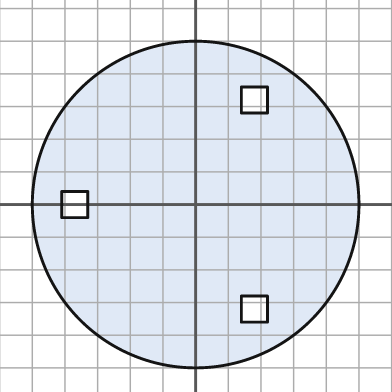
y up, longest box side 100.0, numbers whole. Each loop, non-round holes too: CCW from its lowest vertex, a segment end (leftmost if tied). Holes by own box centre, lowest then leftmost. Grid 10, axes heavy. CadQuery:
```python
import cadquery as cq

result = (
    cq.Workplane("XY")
    .moveTo(0.0, 0.0)
    .circle(50.0)
    .moveTo(14.0, -36.0)
    .lineTo(22.0, -36.0)
    .lineTo(22.0, -28.0)
    .lineTo(14.0, -28.0)
    .close()
    .moveTo(-41.0, -4.0)
    .lineTo(-33.0, -4.0)
    .lineTo(-33.0, 4.0)
    .lineTo(-41.0, 4.0)
    .close()
    .moveTo(14.0, 28.0)
    .lineTo(22.0, 28.0)
    .lineTo(22.0, 36.0)
    .lineTo(14.0, 36.0)
    .close()
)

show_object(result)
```